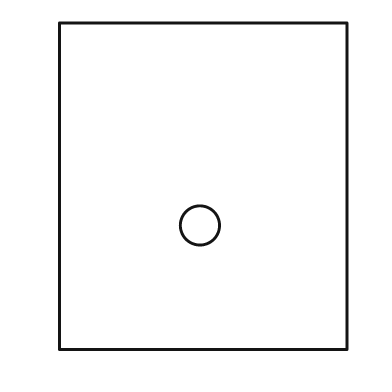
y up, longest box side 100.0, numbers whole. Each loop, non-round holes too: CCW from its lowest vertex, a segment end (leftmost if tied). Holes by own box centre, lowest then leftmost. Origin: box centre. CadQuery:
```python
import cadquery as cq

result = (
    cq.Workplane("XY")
    .moveTo(-44.0, -50.0)
    .lineTo(44.0, -50.0)
    .lineTo(44.0, 50.0)
    .lineTo(-44.0, 50.0)
    .close()
    .moveTo(-1.0, -12.0)
    .circle(6.0)
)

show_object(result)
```